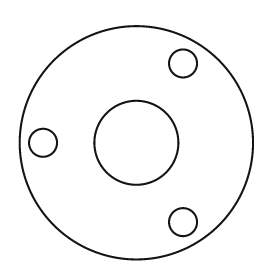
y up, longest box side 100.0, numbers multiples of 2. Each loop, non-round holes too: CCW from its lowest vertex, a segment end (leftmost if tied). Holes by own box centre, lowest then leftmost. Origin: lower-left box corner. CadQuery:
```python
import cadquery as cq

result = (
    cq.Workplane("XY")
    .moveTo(50.0, 50.0)
    .circle(50.0)
    .moveTo(70.0, 16.0)
    .circle(6.0)
    .moveTo(10.0, 50.0)
    .circle(6.0)
    .moveTo(50.0, 50.0)
    .circle(18.0)
    .moveTo(70.0, 84.0)
    .circle(6.0)
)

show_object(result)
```